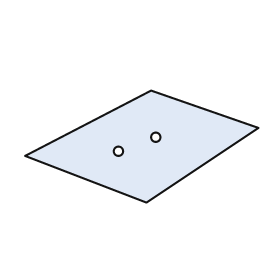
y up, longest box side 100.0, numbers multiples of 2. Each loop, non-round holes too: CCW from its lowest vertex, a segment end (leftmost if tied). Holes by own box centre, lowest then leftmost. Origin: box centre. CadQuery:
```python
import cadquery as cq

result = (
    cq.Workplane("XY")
    .moveTo(2.0, -24.0)
    .lineTo(50.0, 8.0)
    .lineTo(4.0, 24.0)
    .lineTo(-50.0, -4.0)
    .close()
    .moveTo(-10.0, -2.0)
    .circle(2.0)
    .moveTo(6.0, 4.0)
    .circle(2.0)
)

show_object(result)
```